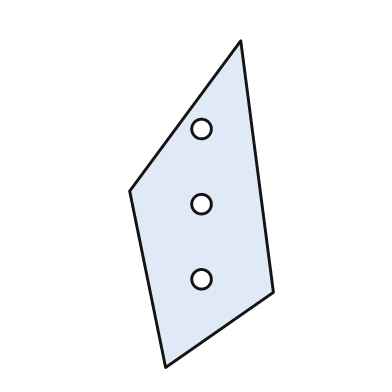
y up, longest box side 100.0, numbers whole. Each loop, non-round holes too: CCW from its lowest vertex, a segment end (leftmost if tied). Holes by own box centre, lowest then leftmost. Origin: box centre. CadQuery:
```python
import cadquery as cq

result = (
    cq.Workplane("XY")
    .moveTo(-11.0, -50.0)
    .lineTo(22.0, -27.0)
    .lineTo(12.0, 50.0)
    .lineTo(-22.0, 4.0)
    .close()
    .moveTo(0.0, -23.0)
    .circle(3.0)
    .moveTo(0.0, 0.0)
    .circle(3.0)
    .moveTo(0.0, 23.0)
    .circle(3.0)
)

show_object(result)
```